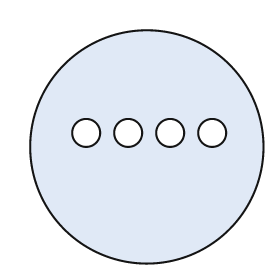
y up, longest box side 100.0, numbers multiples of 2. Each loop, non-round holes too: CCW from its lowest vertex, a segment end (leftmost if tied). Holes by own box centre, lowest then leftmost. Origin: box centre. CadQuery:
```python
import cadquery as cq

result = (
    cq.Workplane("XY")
    .moveTo(0.0, 0.0)
    .circle(50.0)
    .moveTo(-26.0, 6.0)
    .circle(6.0)
    .moveTo(-8.0, 6.0)
    .circle(6.0)
    .moveTo(10.0, 6.0)
    .circle(6.0)
    .moveTo(28.0, 6.0)
    .circle(6.0)
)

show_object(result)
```